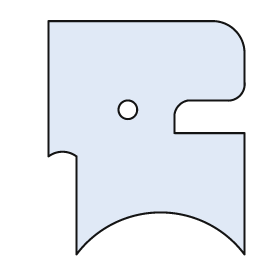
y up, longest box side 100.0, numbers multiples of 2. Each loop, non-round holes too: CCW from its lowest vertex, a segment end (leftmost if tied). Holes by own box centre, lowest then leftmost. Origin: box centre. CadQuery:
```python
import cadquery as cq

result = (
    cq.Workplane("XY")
    .moveTo(-30.0, -50.0)
    .threePointArc((6.0, -32.0), (42.0, -50.0))
    .lineTo(42.0, 2.0)
    .lineTo(12.0, 2.0)
    .lineTo(12.0, 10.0)
    .threePointArc((14.0, 14.0), (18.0, 16.0))
    .lineTo(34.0, 16.0)
    .threePointArc((40.0, 18.0), (42.0, 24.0))
    .lineTo(42.0, 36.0)
    .threePointArc((38.0, 46.0), (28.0, 50.0))
    .lineTo(-42.0, 50.0)
    .lineTo(-42.0, -8.0)
    .threePointArc((-36.0, -6.0), (-30.0, -8.0))
    .close()
    .moveTo(-8.0, 12.0)
    .circle(4.0)
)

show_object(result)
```